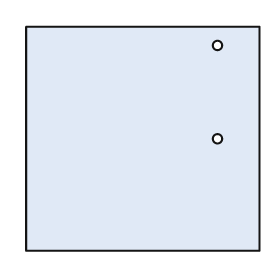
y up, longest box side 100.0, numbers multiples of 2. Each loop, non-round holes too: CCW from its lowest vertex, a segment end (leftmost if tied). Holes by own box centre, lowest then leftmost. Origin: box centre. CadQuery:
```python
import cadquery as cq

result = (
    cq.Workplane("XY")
    .moveTo(-50.0, -48.0)
    .lineTo(50.0, -48.0)
    .lineTo(50.0, 48.0)
    .lineTo(-50.0, 48.0)
    .close()
    .moveTo(32.0, 0.0)
    .circle(2.0)
    .moveTo(32.0, 40.0)
    .circle(2.0)
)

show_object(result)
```